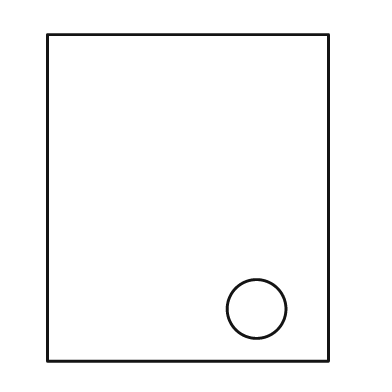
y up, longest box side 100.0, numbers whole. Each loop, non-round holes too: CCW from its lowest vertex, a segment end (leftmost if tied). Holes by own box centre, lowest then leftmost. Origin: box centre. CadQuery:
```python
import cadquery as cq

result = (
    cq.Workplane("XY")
    .moveTo(-43.0, -50.0)
    .lineTo(43.0, -50.0)
    .lineTo(43.0, 50.0)
    .lineTo(-43.0, 50.0)
    .close()
    .moveTo(21.0, -34.0)
    .circle(9.0)
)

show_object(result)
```